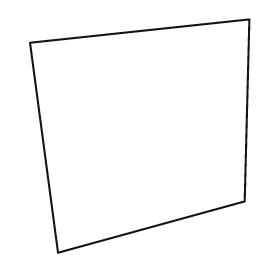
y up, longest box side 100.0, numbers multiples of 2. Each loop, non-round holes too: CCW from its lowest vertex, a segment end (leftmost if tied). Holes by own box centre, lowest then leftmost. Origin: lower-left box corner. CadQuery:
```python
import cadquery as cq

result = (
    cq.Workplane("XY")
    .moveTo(12.0, 0.0)
    .lineTo(92.0, 22.0)
    .lineTo(94.0, 100.0)
    .lineTo(0.0, 90.0)
    .close()
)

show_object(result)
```